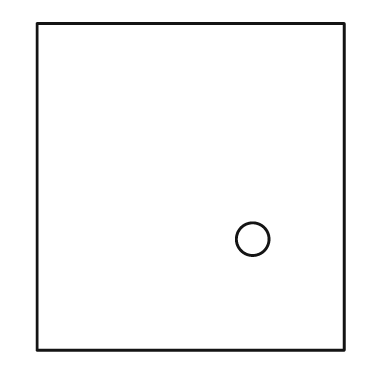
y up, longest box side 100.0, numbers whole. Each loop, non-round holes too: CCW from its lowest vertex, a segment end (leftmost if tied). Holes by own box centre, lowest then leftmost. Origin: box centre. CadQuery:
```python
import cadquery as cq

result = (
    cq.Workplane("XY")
    .moveTo(-47.0, -50.0)
    .lineTo(47.0, -50.0)
    .lineTo(47.0, 50.0)
    .lineTo(-47.0, 50.0)
    .close()
    .moveTo(19.0, -16.0)
    .circle(5.0)
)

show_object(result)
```